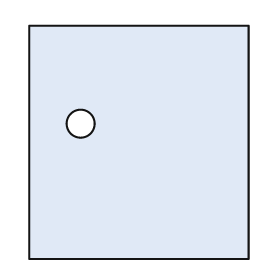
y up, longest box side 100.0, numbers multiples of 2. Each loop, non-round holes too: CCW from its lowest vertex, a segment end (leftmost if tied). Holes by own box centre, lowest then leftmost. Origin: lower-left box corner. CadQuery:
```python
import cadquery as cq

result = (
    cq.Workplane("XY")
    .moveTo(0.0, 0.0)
    .lineTo(94.0, 0.0)
    .lineTo(94.0, 100.0)
    .lineTo(0.0, 100.0)
    .close()
    .moveTo(22.0, 58.0)
    .circle(6.0)
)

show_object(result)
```